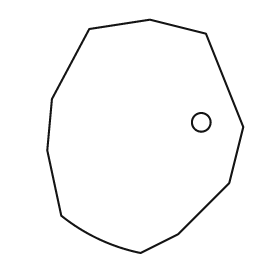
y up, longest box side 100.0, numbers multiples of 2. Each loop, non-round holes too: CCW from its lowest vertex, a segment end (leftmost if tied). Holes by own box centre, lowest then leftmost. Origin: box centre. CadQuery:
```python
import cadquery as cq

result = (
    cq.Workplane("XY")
    .moveTo(-2.0, -50.0)
    .lineTo(14.0, -42.0)
    .lineTo(36.0, -20.0)
    .lineTo(42.0, 4.0)
    .lineTo(26.0, 44.0)
    .lineTo(2.0, 50.0)
    .lineTo(-24.0, 46.0)
    .lineTo(-40.0, 16.0)
    .lineTo(-42.0, -6.0)
    .lineTo(-36.0, -34.0)
    .threePointArc((-20.0, -44.0), (-2.0, -50.0))
    .close()
    .moveTo(24.0, 6.0)
    .circle(4.0)
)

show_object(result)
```